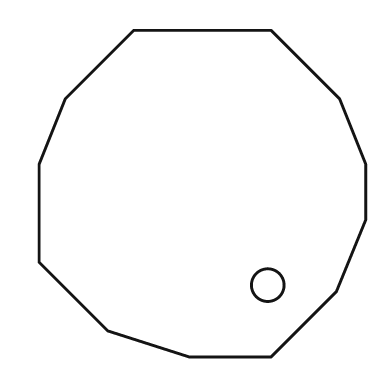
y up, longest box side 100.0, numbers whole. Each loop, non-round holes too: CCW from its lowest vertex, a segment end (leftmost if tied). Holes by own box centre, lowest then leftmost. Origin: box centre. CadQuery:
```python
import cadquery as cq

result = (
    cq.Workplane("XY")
    .moveTo(-4.0, -50.0)
    .lineTo(21.0, -50.0)
    .lineTo(41.0, -30.0)
    .lineTo(50.0, -8.0)
    .lineTo(50.0, 9.0)
    .lineTo(42.0, 29.0)
    .lineTo(21.0, 50.0)
    .lineTo(-21.0, 50.0)
    .lineTo(-42.0, 29.0)
    .lineTo(-50.0, 9.0)
    .lineTo(-50.0, -21.0)
    .lineTo(-29.0, -42.0)
    .close()
    .moveTo(20.0, -28.0)
    .circle(5.0)
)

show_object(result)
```